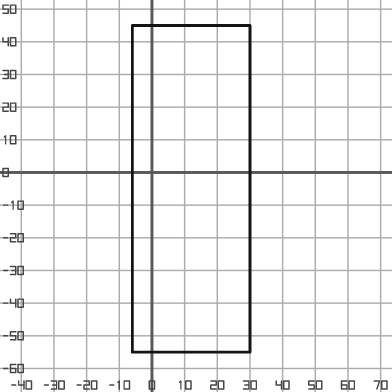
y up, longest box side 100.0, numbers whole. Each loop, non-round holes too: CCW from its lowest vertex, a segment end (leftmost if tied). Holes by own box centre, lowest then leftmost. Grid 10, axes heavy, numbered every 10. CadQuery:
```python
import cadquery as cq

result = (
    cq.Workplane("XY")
    .moveTo(-6.0, -55.0)
    .lineTo(30.0, -55.0)
    .lineTo(30.0, 45.0)
    .lineTo(-6.0, 45.0)
    .close()
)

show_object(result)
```